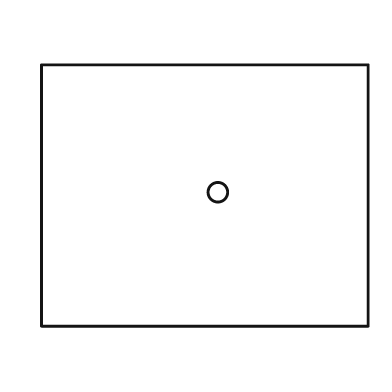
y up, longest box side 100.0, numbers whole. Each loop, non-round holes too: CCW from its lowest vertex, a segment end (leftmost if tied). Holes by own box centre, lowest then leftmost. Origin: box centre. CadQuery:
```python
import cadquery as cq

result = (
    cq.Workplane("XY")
    .moveTo(-50.0, -40.0)
    .lineTo(50.0, -40.0)
    .lineTo(50.0, 40.0)
    .lineTo(-50.0, 40.0)
    .close()
    .moveTo(4.0, 1.0)
    .circle(3.0)
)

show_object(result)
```